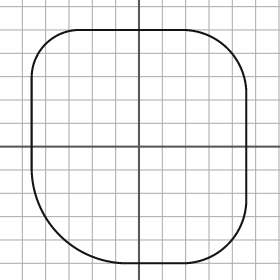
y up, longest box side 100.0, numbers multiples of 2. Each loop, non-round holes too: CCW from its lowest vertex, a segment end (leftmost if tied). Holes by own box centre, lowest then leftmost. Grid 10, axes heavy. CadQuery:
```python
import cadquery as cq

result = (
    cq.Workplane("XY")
    .moveTo(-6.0, -50.0)
    .lineTo(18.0, -50.0)
    .threePointArc((38.0, -42.0), (46.0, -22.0))
    .lineTo(46.0, 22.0)
    .threePointArc((38.0, 42.0), (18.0, 50.0))
    .lineTo(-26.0, 50.0)
    .threePointArc((-40.0, 44.0), (-46.0, 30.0))
    .lineTo(-46.0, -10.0)
    .threePointArc((-34.0, -38.0), (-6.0, -50.0))
    .close()
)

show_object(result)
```